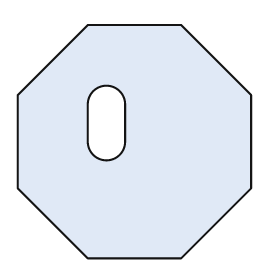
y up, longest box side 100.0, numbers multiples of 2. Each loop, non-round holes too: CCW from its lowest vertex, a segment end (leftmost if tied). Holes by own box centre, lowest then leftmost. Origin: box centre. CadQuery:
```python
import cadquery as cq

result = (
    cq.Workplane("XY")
    .moveTo(-20.0, -50.0)
    .lineTo(20.0, -50.0)
    .lineTo(50.0, -20.0)
    .lineTo(50.0, 20.0)
    .lineTo(20.0, 50.0)
    .lineTo(-20.0, 50.0)
    .lineTo(-50.0, 20.0)
    .lineTo(-50.0, -20.0)
    .close()
    .moveTo(-20.0, 0.0)
    .threePointArc((-12.0, -8.0), (-4.0, 0.0))
    .lineTo(-4.0, 16.0)
    .threePointArc((-12.0, 24.0), (-20.0, 16.0))
    .close()
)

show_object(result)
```